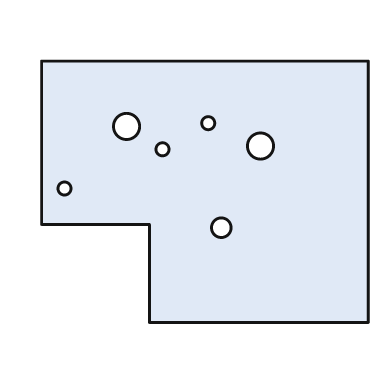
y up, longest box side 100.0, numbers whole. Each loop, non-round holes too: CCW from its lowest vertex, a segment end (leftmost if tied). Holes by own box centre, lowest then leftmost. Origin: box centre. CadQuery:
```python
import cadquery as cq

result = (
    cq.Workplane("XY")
    .moveTo(-17.0, -40.0)
    .lineTo(50.0, -40.0)
    .lineTo(50.0, 40.0)
    .lineTo(-50.0, 40.0)
    .lineTo(-50.0, -10.0)
    .lineTo(-17.0, -10.0)
    .close()
    .moveTo(5.0, -11.0)
    .circle(3.0)
    .moveTo(-43.0, 1.0)
    .circle(2.0)
    .moveTo(-13.0, 13.0)
    .circle(2.0)
    .moveTo(17.0, 14.0)
    .circle(4.0)
    .moveTo(-24.0, 20.0)
    .circle(4.0)
    .moveTo(1.0, 21.0)
    .circle(2.0)
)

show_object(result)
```